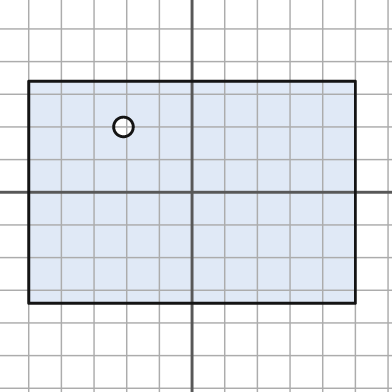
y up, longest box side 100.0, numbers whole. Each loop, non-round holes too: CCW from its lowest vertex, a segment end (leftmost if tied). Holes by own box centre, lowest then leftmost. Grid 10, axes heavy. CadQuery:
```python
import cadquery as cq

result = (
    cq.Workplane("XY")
    .moveTo(-50.0, -34.0)
    .lineTo(50.0, -34.0)
    .lineTo(50.0, 34.0)
    .lineTo(-50.0, 34.0)
    .close()
    .moveTo(-21.0, 20.0)
    .circle(3.0)
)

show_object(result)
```